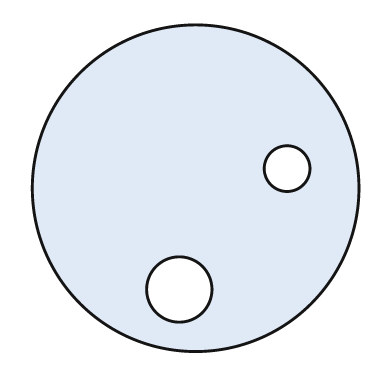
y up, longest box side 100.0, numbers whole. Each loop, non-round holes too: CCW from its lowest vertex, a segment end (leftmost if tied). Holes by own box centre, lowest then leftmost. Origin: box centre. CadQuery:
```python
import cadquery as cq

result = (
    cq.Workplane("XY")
    .moveTo(0.0, 0.0)
    .circle(50.0)
    .moveTo(-5.0, -31.0)
    .circle(10.0)
    .moveTo(28.0, 6.0)
    .circle(7.0)
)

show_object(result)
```